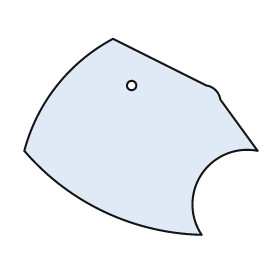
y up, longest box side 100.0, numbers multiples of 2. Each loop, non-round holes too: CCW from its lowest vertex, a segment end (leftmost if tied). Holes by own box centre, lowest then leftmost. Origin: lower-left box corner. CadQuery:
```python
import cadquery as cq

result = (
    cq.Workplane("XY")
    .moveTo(76.0, 0.0)
    .threePointArc((76.0, 26.0), (100.0, 36.0))
    .lineTo(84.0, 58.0)
    .threePointArc((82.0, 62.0), (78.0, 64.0))
    .lineTo(38.0, 84.0)
    .threePointArc((14.0, 64.0), (0.0, 36.0))
    .threePointArc((34.0, 10.0), (76.0, 0.0))
    .close()
    .moveTo(46.0, 64.0)
    .circle(2.0)
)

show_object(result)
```